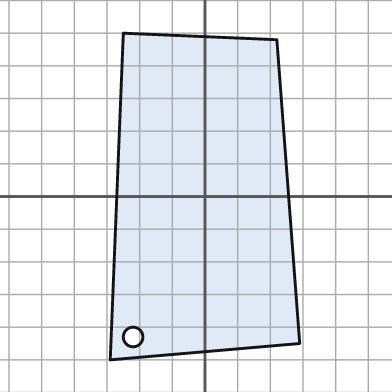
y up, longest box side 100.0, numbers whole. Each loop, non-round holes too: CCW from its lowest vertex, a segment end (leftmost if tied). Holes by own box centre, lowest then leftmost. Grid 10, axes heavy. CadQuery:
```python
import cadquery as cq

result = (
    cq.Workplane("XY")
    .moveTo(-29.0, -50.0)
    .lineTo(29.0, -45.0)
    .lineTo(22.0, 48.0)
    .lineTo(-25.0, 50.0)
    .close()
    .moveTo(-22.0, -43.0)
    .circle(3.0)
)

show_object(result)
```